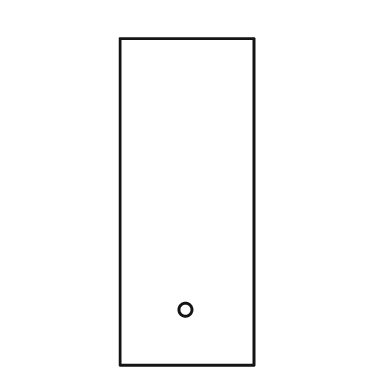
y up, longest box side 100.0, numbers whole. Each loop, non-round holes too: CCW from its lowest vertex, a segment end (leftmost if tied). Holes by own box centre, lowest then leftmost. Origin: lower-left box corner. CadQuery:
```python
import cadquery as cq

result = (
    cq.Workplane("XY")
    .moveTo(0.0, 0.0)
    .lineTo(41.0, 0.0)
    .lineTo(41.0, 100.0)
    .lineTo(0.0, 100.0)
    .close()
    .moveTo(20.0, 17.0)
    .circle(2.0)
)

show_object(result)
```